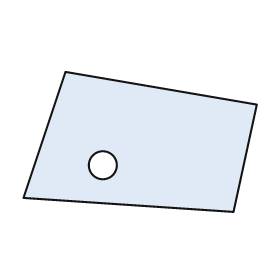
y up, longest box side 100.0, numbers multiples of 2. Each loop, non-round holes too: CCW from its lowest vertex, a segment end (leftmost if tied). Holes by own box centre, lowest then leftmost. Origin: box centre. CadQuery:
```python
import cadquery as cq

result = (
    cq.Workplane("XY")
    .moveTo(40.0, -30.0)
    .lineTo(50.0, 16.0)
    .lineTo(-32.0, 30.0)
    .lineTo(-50.0, -24.0)
    .close()
    .moveTo(-16.0, -10.0)
    .circle(6.0)
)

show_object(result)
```